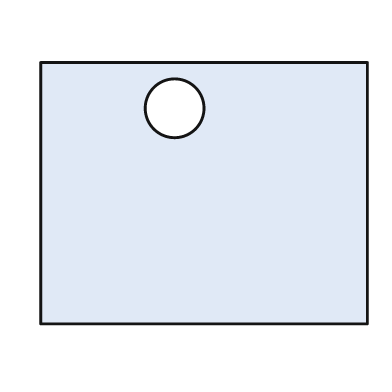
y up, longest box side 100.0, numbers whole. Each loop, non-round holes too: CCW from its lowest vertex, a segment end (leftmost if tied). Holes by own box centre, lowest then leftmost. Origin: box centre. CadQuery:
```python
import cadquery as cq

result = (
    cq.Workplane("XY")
    .moveTo(-50.0, -40.0)
    .lineTo(50.0, -40.0)
    .lineTo(50.0, 40.0)
    .lineTo(-50.0, 40.0)
    .close()
    .moveTo(-9.0, 26.0)
    .circle(9.0)
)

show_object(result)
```